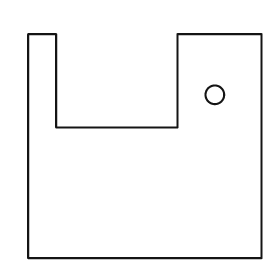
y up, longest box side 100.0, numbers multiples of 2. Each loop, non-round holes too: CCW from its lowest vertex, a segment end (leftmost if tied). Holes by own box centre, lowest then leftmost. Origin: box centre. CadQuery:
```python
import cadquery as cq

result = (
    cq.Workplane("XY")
    .moveTo(-50.0, -48.0)
    .lineTo(50.0, -48.0)
    .lineTo(50.0, 48.0)
    .lineTo(14.0, 48.0)
    .lineTo(14.0, 8.0)
    .lineTo(-38.0, 8.0)
    .lineTo(-38.0, 48.0)
    .lineTo(-50.0, 48.0)
    .close()
    .moveTo(30.0, 22.0)
    .circle(4.0)
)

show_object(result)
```